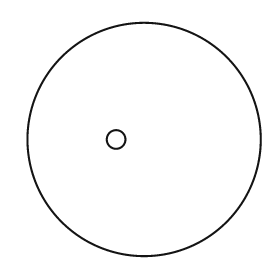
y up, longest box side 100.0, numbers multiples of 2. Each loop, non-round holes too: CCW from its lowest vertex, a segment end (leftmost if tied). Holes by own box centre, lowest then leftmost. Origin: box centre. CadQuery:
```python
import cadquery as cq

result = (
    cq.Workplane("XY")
    .moveTo(0.0, 0.0)
    .circle(50.0)
    .moveTo(-12.0, 0.0)
    .circle(4.0)
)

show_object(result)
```